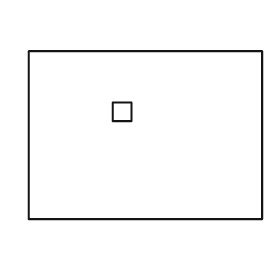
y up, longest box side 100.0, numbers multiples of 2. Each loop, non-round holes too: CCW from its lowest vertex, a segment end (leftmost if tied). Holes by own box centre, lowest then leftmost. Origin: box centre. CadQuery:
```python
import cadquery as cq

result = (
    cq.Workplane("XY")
    .moveTo(-50.0, -36.0)
    .lineTo(50.0, -36.0)
    .lineTo(50.0, 36.0)
    .lineTo(-50.0, 36.0)
    .close()
    .moveTo(-14.0, 6.0)
    .lineTo(-6.0, 6.0)
    .lineTo(-6.0, 14.0)
    .lineTo(-14.0, 14.0)
    .close()
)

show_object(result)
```